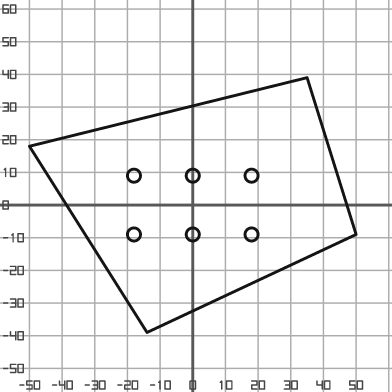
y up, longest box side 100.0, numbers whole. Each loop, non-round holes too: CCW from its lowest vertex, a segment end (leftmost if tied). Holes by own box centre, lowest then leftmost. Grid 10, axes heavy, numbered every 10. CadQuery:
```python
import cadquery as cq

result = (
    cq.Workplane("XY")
    .moveTo(-14.0, -39.0)
    .lineTo(50.0, -9.0)
    .lineTo(35.0, 39.0)
    .lineTo(-50.0, 18.0)
    .close()
    .moveTo(-18.0, -9.0)
    .circle(2.0)
    .moveTo(0.0, -9.0)
    .circle(2.0)
    .moveTo(18.0, -9.0)
    .circle(2.0)
    .moveTo(-18.0, 9.0)
    .circle(2.0)
    .moveTo(0.0, 9.0)
    .circle(2.0)
    .moveTo(18.0, 9.0)
    .circle(2.0)
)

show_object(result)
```